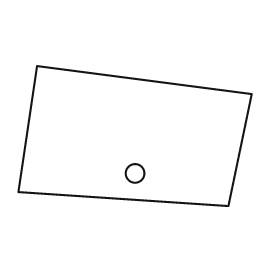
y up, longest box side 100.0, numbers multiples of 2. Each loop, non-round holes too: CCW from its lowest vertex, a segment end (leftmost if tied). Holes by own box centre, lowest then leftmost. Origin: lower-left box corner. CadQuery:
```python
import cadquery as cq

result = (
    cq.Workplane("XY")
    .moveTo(90.0, 0.0)
    .lineTo(100.0, 48.0)
    .lineTo(8.0, 60.0)
    .lineTo(0.0, 6.0)
    .close()
    .moveTo(50.0, 14.0)
    .circle(4.0)
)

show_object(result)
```